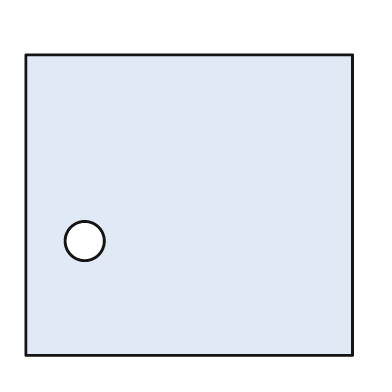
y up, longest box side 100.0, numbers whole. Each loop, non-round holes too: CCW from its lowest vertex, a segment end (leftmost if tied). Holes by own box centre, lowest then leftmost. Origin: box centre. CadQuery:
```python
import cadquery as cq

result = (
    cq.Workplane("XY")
    .moveTo(-50.0, -46.0)
    .lineTo(50.0, -46.0)
    .lineTo(50.0, 46.0)
    .lineTo(-50.0, 46.0)
    .close()
    .moveTo(-32.0, -11.0)
    .circle(6.0)
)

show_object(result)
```